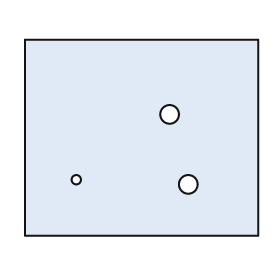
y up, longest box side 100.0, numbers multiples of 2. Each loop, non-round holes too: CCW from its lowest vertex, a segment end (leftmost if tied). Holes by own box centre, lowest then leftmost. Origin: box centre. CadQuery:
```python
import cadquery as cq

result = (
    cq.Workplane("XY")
    .moveTo(-50.0, -42.0)
    .lineTo(50.0, -42.0)
    .lineTo(50.0, 42.0)
    .lineTo(-50.0, 42.0)
    .close()
    .moveTo(20.0, -20.0)
    .circle(4.0)
    .moveTo(-28.0, -18.0)
    .circle(2.0)
    .moveTo(12.0, 10.0)
    .circle(4.0)
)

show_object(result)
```